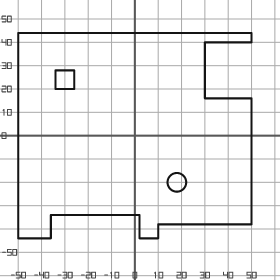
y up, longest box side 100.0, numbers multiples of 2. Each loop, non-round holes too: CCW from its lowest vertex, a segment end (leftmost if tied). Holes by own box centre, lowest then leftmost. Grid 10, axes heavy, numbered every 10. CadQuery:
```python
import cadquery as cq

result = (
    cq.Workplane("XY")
    .moveTo(-50.0, -44.0)
    .lineTo(-36.0, -44.0)
    .lineTo(-36.0, -34.0)
    .lineTo(2.0, -34.0)
    .lineTo(2.0, -44.0)
    .lineTo(10.0, -44.0)
    .lineTo(10.0, -38.0)
    .lineTo(50.0, -38.0)
    .lineTo(50.0, 16.0)
    .lineTo(30.0, 16.0)
    .lineTo(30.0, 40.0)
    .lineTo(50.0, 40.0)
    .lineTo(50.0, 44.0)
    .lineTo(-50.0, 44.0)
    .close()
    .moveTo(18.0, -20.0)
    .circle(4.0)
    .moveTo(-34.0, 20.0)
    .lineTo(-26.0, 20.0)
    .lineTo(-26.0, 28.0)
    .lineTo(-34.0, 28.0)
    .close()
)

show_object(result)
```